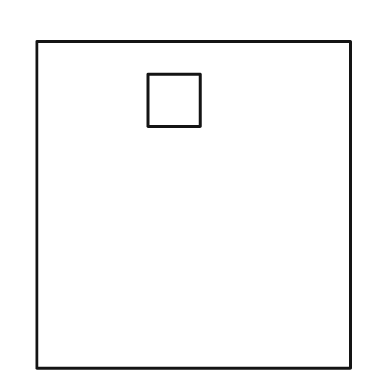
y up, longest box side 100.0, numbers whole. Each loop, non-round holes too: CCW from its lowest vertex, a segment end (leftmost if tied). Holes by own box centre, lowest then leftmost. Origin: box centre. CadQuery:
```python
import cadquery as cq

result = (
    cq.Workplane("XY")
    .moveTo(-48.0, -50.0)
    .lineTo(48.0, -50.0)
    .lineTo(48.0, 50.0)
    .lineTo(-48.0, 50.0)
    .close()
    .moveTo(-14.0, 24.0)
    .lineTo(2.0, 24.0)
    .lineTo(2.0, 40.0)
    .lineTo(-14.0, 40.0)
    .close()
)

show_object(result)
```